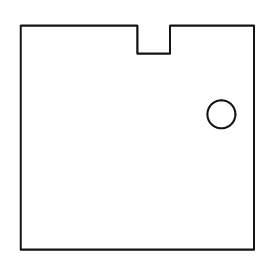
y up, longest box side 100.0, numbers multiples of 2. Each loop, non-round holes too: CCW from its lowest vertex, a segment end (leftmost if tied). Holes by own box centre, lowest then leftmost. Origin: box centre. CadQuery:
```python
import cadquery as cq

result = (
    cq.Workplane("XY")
    .moveTo(-50.0, -48.0)
    .lineTo(50.0, -48.0)
    .lineTo(50.0, 48.0)
    .lineTo(14.0, 48.0)
    .lineTo(14.0, 36.0)
    .lineTo(0.0, 36.0)
    .lineTo(0.0, 48.0)
    .lineTo(-50.0, 48.0)
    .close()
    .moveTo(36.0, 10.0)
    .circle(6.0)
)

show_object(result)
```